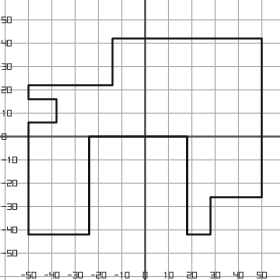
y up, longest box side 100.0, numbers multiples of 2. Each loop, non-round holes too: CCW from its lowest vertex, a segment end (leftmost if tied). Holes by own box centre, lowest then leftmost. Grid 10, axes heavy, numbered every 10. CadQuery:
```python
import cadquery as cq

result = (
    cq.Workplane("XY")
    .moveTo(-50.0, -42.0)
    .lineTo(-24.0, -42.0)
    .lineTo(-24.0, 0.0)
    .lineTo(18.0, 0.0)
    .lineTo(18.0, -42.0)
    .lineTo(28.0, -42.0)
    .lineTo(28.0, -26.0)
    .lineTo(50.0, -26.0)
    .lineTo(50.0, 42.0)
    .lineTo(-14.0, 42.0)
    .lineTo(-14.0, 22.0)
    .lineTo(-50.0, 22.0)
    .lineTo(-50.0, 16.0)
    .lineTo(-38.0, 16.0)
    .lineTo(-38.0, 6.0)
    .lineTo(-50.0, 6.0)
    .close()
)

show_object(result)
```